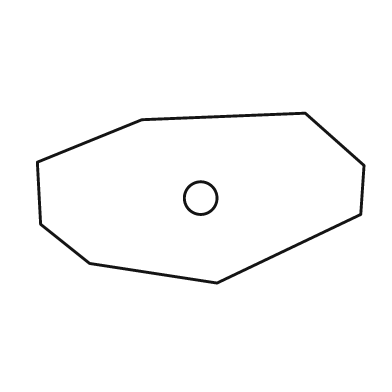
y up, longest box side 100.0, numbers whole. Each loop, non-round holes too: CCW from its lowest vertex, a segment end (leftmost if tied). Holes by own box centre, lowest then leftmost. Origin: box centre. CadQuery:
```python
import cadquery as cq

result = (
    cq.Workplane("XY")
    .moveTo(5.0, -26.0)
    .lineTo(49.0, -5.0)
    .lineTo(50.0, 10.0)
    .lineTo(32.0, 26.0)
    .lineTo(-18.0, 24.0)
    .lineTo(-50.0, 11.0)
    .lineTo(-49.0, -8.0)
    .lineTo(-34.0, -20.0)
    .close()
    .moveTo(0.0, 0.0)
    .circle(5.0)
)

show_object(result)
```